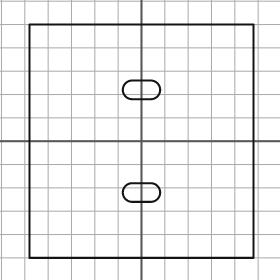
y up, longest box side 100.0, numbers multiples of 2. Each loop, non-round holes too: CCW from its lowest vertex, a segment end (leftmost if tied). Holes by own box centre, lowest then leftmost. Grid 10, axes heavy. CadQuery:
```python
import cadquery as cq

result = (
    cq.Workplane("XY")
    .moveTo(-48.0, -50.0)
    .lineTo(48.0, -50.0)
    .lineTo(48.0, 50.0)
    .lineTo(-48.0, 50.0)
    .close()
    .moveTo(-4.0, -26.0)
    .lineTo(4.0, -26.0)
    .threePointArc((8.0, -22.0), (4.0, -18.0))
    .lineTo(-4.0, -18.0)
    .threePointArc((-8.0, -22.0), (-4.0, -26.0))
    .close()
    .moveTo(-4.0, 18.0)
    .lineTo(4.0, 18.0)
    .threePointArc((8.0, 22.0), (4.0, 26.0))
    .lineTo(-4.0, 26.0)
    .threePointArc((-8.0, 22.0), (-4.0, 18.0))
    .close()
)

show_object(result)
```